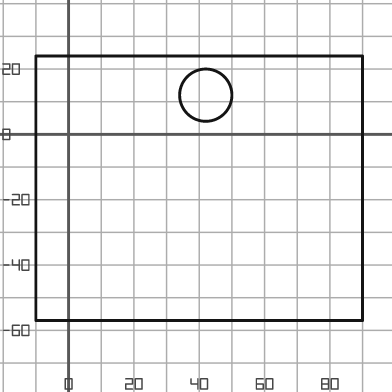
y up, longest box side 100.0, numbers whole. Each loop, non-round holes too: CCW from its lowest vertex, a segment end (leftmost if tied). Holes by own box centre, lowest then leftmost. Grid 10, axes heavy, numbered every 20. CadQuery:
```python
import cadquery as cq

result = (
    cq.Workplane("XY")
    .moveTo(-10.0, -57.0)
    .lineTo(90.0, -57.0)
    .lineTo(90.0, 24.0)
    .lineTo(-10.0, 24.0)
    .close()
    .moveTo(42.0, 12.0)
    .circle(8.0)
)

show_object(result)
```